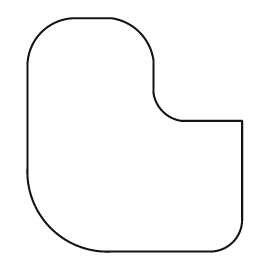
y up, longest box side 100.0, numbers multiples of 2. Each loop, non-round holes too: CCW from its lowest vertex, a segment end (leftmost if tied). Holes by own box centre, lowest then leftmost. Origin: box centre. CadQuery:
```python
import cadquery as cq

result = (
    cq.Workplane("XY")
    .moveTo(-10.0, -50.0)
    .lineTo(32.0, -50.0)
    .threePointArc((42.0, -46.0), (46.0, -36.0))
    .lineTo(46.0, 6.0)
    .lineTo(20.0, 6.0)
    .threePointArc((12.0, 10.0), (8.0, 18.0))
    .lineTo(8.0, 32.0)
    .threePointArc((2.0, 44.0), (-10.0, 50.0))
    .lineTo(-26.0, 50.0)
    .threePointArc((-40.0, 44.0), (-46.0, 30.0))
    .lineTo(-46.0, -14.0)
    .threePointArc((-36.0, -40.0), (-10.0, -50.0))
    .close()
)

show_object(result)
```